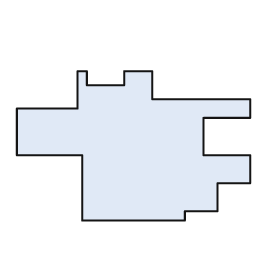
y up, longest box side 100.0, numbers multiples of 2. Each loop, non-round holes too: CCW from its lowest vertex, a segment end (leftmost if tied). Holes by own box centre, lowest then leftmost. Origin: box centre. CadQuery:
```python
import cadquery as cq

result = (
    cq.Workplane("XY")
    .moveTo(-22.0, -32.0)
    .lineTo(22.0, -32.0)
    .lineTo(22.0, -28.0)
    .lineTo(36.0, -28.0)
    .lineTo(36.0, -16.0)
    .lineTo(50.0, -16.0)
    .lineTo(50.0, -4.0)
    .lineTo(30.0, -4.0)
    .lineTo(30.0, 12.0)
    .lineTo(50.0, 12.0)
    .lineTo(50.0, 20.0)
    .lineTo(8.0, 20.0)
    .lineTo(8.0, 32.0)
    .lineTo(-4.0, 32.0)
    .lineTo(-4.0, 26.0)
    .lineTo(-20.0, 26.0)
    .lineTo(-20.0, 32.0)
    .lineTo(-24.0, 32.0)
    .lineTo(-24.0, 16.0)
    .lineTo(-50.0, 16.0)
    .lineTo(-50.0, -4.0)
    .lineTo(-22.0, -4.0)
    .close()
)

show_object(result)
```